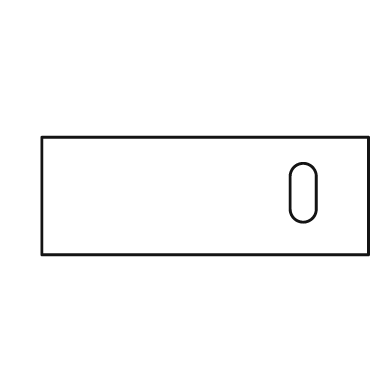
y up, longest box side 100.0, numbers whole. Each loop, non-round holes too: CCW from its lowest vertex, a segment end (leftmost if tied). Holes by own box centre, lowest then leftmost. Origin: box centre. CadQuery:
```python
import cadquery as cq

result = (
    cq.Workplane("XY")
    .moveTo(-50.0, -18.0)
    .lineTo(50.0, -18.0)
    .lineTo(50.0, 18.0)
    .lineTo(-50.0, 18.0)
    .close()
    .moveTo(26.0, -4.0)
    .threePointArc((30.0, -8.0), (34.0, -4.0))
    .lineTo(34.0, 6.0)
    .threePointArc((30.0, 10.0), (26.0, 6.0))
    .close()
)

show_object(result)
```